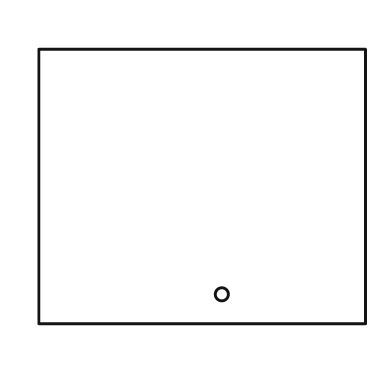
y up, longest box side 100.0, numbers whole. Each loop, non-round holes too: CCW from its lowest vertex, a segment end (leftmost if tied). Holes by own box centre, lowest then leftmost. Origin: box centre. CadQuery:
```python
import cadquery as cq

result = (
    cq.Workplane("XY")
    .moveTo(-50.0, -42.0)
    .lineTo(50.0, -42.0)
    .lineTo(50.0, 42.0)
    .lineTo(-50.0, 42.0)
    .close()
    .moveTo(6.0, -33.0)
    .circle(2.0)
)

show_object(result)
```